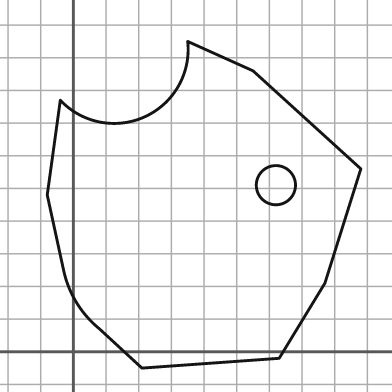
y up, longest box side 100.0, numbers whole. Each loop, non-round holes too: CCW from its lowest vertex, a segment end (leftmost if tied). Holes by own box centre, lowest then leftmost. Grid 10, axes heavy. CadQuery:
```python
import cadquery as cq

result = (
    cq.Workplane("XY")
    .moveTo(21.0, -5.0)
    .lineTo(63.0, -2.0)
    .lineTo(77.0, 21.0)
    .lineTo(88.0, 56.0)
    .lineTo(55.0, 86.0)
    .lineTo(35.0, 95.0)
    .threePointArc((22.0, 72.0), (-4.0, 77.0))
    .lineTo(-8.0, 48.0)
    .lineTo(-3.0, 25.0)
    .threePointArc((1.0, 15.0), (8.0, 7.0))
    .close()
    .moveTo(62.0, 51.0)
    .circle(6.0)
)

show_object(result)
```